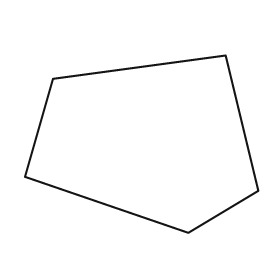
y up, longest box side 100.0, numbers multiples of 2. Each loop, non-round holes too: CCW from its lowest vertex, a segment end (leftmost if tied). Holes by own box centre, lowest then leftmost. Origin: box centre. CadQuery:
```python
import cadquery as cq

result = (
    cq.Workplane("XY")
    .moveTo(20.0, -38.0)
    .lineTo(50.0, -20.0)
    .lineTo(36.0, 38.0)
    .lineTo(-38.0, 28.0)
    .lineTo(-50.0, -14.0)
    .close()
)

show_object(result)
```